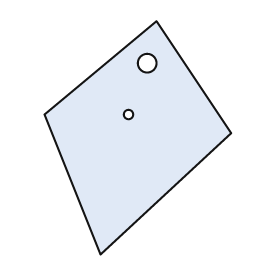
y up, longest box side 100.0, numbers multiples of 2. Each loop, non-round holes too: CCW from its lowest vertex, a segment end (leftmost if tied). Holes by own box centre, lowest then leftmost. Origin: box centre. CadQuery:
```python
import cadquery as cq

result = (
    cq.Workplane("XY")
    .moveTo(-16.0, -50.0)
    .lineTo(40.0, 2.0)
    .lineTo(8.0, 50.0)
    .lineTo(-40.0, 10.0)
    .close()
    .moveTo(-4.0, 10.0)
    .circle(2.0)
    .moveTo(4.0, 32.0)
    .circle(4.0)
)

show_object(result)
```